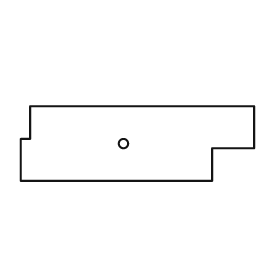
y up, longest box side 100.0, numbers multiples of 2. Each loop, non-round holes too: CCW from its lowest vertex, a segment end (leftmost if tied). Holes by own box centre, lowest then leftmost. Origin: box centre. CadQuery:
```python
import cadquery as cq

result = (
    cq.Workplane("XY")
    .moveTo(-50.0, -16.0)
    .lineTo(32.0, -16.0)
    .lineTo(32.0, -2.0)
    .lineTo(50.0, -2.0)
    .lineTo(50.0, 16.0)
    .lineTo(-46.0, 16.0)
    .lineTo(-46.0, 2.0)
    .lineTo(-50.0, 2.0)
    .close()
    .moveTo(-6.0, 0.0)
    .circle(2.0)
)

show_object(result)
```